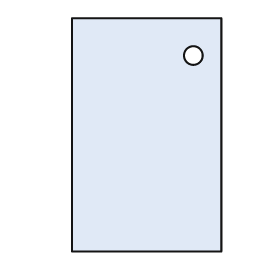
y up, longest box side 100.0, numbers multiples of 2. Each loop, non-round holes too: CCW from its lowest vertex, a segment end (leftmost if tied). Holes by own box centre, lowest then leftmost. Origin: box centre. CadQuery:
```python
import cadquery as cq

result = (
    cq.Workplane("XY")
    .moveTo(-32.0, -50.0)
    .lineTo(32.0, -50.0)
    .lineTo(32.0, 50.0)
    .lineTo(-32.0, 50.0)
    .close()
    .moveTo(20.0, 34.0)
    .circle(4.0)
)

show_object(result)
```